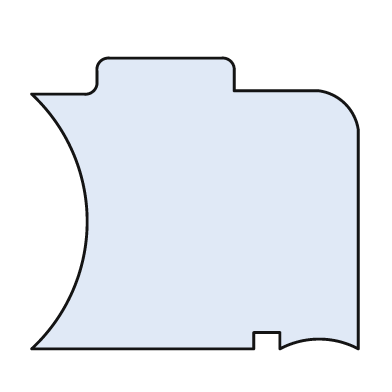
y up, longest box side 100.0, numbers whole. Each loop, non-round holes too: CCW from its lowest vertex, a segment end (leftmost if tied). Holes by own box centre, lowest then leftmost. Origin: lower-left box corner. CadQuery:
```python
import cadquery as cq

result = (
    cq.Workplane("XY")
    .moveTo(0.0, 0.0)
    .lineTo(68.0, 0.0)
    .lineTo(68.0, 5.0)
    .lineTo(76.0, 5.0)
    .lineTo(76.0, 0.0)
    .threePointArc((88.0, 3.0), (100.0, 0.0))
    .lineTo(100.0, 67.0)
    .threePointArc((96.0, 75.0), (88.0, 79.0))
    .lineTo(62.0, 79.0)
    .lineTo(62.0, 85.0)
    .threePointArc((61.0, 88.0), (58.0, 89.0))
    .lineTo(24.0, 89.0)
    .threePointArc((21.0, 88.0), (20.0, 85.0))
    .lineTo(20.0, 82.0)
    .threePointArc((19.0, 79.0), (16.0, 78.0))
    .lineTo(0.0, 78.0)
    .threePointArc((17.0, 39.0), (0.0, 0.0))
    .close()
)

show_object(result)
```